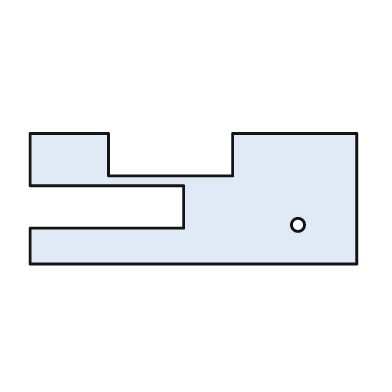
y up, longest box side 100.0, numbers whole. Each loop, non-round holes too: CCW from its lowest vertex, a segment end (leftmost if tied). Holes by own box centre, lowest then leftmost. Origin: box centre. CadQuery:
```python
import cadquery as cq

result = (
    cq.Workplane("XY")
    .moveTo(-50.0, -20.0)
    .lineTo(50.0, -20.0)
    .lineTo(50.0, 20.0)
    .lineTo(12.0, 20.0)
    .lineTo(12.0, 7.0)
    .lineTo(-26.0, 7.0)
    .lineTo(-26.0, 20.0)
    .lineTo(-50.0, 20.0)
    .lineTo(-50.0, 4.0)
    .lineTo(-3.0, 4.0)
    .lineTo(-3.0, -9.0)
    .lineTo(-50.0, -9.0)
    .close()
    .moveTo(32.0, -8.0)
    .circle(2.0)
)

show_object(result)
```